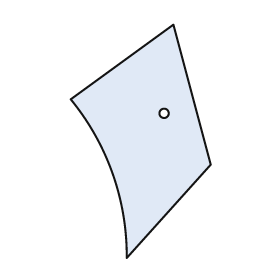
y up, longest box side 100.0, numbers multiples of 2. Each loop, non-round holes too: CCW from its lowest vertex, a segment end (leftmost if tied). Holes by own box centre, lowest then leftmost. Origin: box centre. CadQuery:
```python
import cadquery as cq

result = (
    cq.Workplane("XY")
    .moveTo(-6.0, -50.0)
    .lineTo(30.0, -10.0)
    .lineTo(14.0, 50.0)
    .lineTo(-30.0, 18.0)
    .threePointArc((-12.0, -14.0), (-6.0, -50.0))
    .close()
    .moveTo(10.0, 12.0)
    .circle(2.0)
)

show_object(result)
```